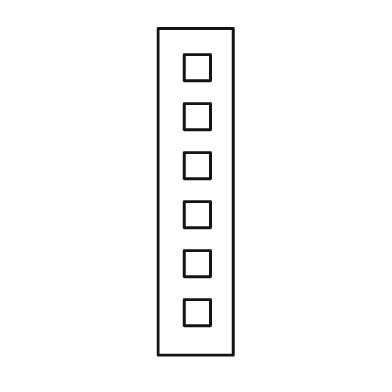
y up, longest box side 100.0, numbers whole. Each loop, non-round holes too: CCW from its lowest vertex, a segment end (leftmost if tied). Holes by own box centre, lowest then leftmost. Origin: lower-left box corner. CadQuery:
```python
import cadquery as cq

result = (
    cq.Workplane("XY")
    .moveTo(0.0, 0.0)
    .lineTo(23.0, 0.0)
    .lineTo(23.0, 100.0)
    .lineTo(0.0, 100.0)
    .close()
    .moveTo(8.0, 9.0)
    .lineTo(16.0, 9.0)
    .lineTo(16.0, 17.0)
    .lineTo(8.0, 17.0)
    .close()
    .moveTo(8.0, 24.0)
    .lineTo(16.0, 24.0)
    .lineTo(16.0, 32.0)
    .lineTo(8.0, 32.0)
    .close()
    .moveTo(8.0, 39.0)
    .lineTo(16.0, 39.0)
    .lineTo(16.0, 47.0)
    .lineTo(8.0, 47.0)
    .close()
    .moveTo(8.0, 54.0)
    .lineTo(16.0, 54.0)
    .lineTo(16.0, 62.0)
    .lineTo(8.0, 62.0)
    .close()
    .moveTo(8.0, 69.0)
    .lineTo(16.0, 69.0)
    .lineTo(16.0, 77.0)
    .lineTo(8.0, 77.0)
    .close()
    .moveTo(8.0, 84.0)
    .lineTo(16.0, 84.0)
    .lineTo(16.0, 92.0)
    .lineTo(8.0, 92.0)
    .close()
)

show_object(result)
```